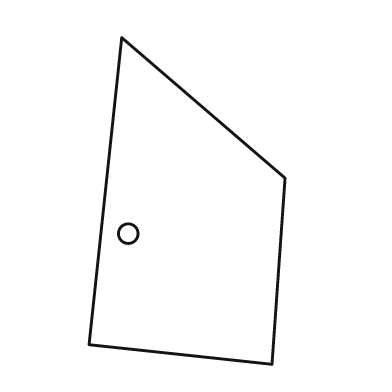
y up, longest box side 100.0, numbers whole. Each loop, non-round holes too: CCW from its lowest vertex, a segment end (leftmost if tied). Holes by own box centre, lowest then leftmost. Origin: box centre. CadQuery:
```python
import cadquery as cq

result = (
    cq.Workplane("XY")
    .moveTo(26.0, -50.0)
    .lineTo(30.0, 7.0)
    .lineTo(-20.0, 50.0)
    .lineTo(-30.0, -44.0)
    .close()
    .moveTo(-18.0, -10.0)
    .circle(3.0)
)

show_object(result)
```